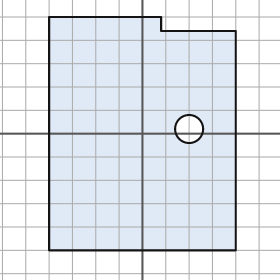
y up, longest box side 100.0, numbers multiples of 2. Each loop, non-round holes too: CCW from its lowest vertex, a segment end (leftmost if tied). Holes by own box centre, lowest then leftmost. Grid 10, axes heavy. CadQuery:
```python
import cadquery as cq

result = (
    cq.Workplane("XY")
    .moveTo(-40.0, -50.0)
    .lineTo(40.0, -50.0)
    .lineTo(40.0, 44.0)
    .lineTo(8.0, 44.0)
    .lineTo(8.0, 50.0)
    .lineTo(-40.0, 50.0)
    .close()
    .moveTo(20.0, 2.0)
    .circle(6.0)
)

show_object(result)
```